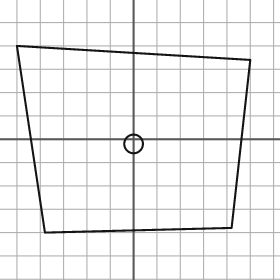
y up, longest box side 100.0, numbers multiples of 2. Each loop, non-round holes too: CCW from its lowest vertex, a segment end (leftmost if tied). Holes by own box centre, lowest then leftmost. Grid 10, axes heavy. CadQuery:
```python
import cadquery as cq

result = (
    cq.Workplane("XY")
    .moveTo(-38.0, -40.0)
    .lineTo(42.0, -38.0)
    .lineTo(50.0, 34.0)
    .lineTo(-50.0, 40.0)
    .close()
    .moveTo(0.0, -2.0)
    .circle(4.0)
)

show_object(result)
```